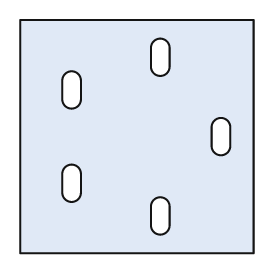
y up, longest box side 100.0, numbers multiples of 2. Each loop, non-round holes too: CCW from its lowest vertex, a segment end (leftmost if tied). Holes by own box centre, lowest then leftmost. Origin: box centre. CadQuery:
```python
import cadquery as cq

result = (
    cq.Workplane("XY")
    .moveTo(-50.0, -50.0)
    .lineTo(50.0, -50.0)
    .lineTo(50.0, 50.0)
    .lineTo(-50.0, 50.0)
    .close()
    .moveTo(6.0, -38.0)
    .threePointArc((10.0, -42.0), (14.0, -38.0))
    .lineTo(14.0, -30.0)
    .threePointArc((10.0, -26.0), (6.0, -30.0))
    .close()
    .moveTo(-32.0, -24.0)
    .threePointArc((-28.0, -28.0), (-24.0, -24.0))
    .lineTo(-24.0, -16.0)
    .threePointArc((-28.0, -12.0), (-32.0, -16.0))
    .close()
    .moveTo(32.0, -4.0)
    .threePointArc((36.0, -8.0), (40.0, -4.0))
    .lineTo(40.0, 4.0)
    .threePointArc((36.0, 8.0), (32.0, 4.0))
    .close()
    .moveTo(-32.0, 16.0)
    .threePointArc((-28.0, 12.0), (-24.0, 16.0))
    .lineTo(-24.0, 24.0)
    .threePointArc((-28.0, 28.0), (-32.0, 24.0))
    .close()
    .moveTo(6.0, 30.0)
    .threePointArc((10.0, 26.0), (14.0, 30.0))
    .lineTo(14.0, 38.0)
    .threePointArc((10.0, 42.0), (6.0, 38.0))
    .close()
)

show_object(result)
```